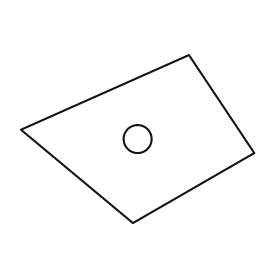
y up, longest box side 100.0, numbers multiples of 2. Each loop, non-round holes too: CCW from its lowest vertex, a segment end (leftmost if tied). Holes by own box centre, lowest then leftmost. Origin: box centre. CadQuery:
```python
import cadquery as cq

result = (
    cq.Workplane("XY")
    .moveTo(-2.0, -36.0)
    .lineTo(50.0, -6.0)
    .lineTo(22.0, 36.0)
    .lineTo(-50.0, 4.0)
    .close()
    .moveTo(0.0, 0.0)
    .circle(6.0)
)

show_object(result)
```